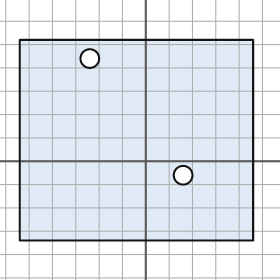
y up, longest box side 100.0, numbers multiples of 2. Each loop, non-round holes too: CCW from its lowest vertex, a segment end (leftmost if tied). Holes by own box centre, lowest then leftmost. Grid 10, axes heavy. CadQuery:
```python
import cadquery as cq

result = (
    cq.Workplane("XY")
    .moveTo(-54.0, -34.0)
    .lineTo(46.0, -34.0)
    .lineTo(46.0, 52.0)
    .lineTo(-54.0, 52.0)
    .close()
    .moveTo(16.0, -6.0)
    .circle(4.0)
    .moveTo(-24.0, 44.0)
    .circle(4.0)
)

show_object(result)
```